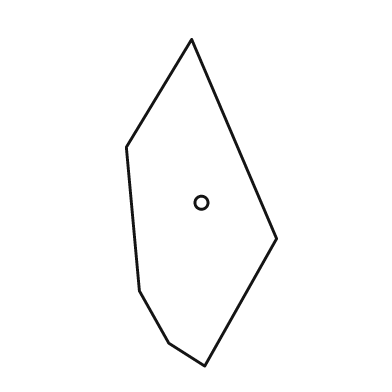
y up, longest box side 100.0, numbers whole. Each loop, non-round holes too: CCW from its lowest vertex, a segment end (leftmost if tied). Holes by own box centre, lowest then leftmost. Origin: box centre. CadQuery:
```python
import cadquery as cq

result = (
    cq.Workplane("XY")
    .moveTo(1.0, -50.0)
    .lineTo(23.0, -11.0)
    .lineTo(-3.0, 50.0)
    .lineTo(-23.0, 17.0)
    .lineTo(-19.0, -27.0)
    .lineTo(-10.0, -43.0)
    .close()
    .moveTo(0.0, 0.0)
    .circle(2.0)
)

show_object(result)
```